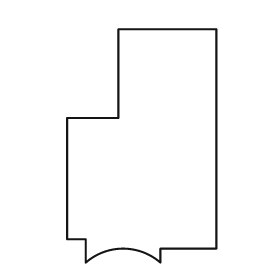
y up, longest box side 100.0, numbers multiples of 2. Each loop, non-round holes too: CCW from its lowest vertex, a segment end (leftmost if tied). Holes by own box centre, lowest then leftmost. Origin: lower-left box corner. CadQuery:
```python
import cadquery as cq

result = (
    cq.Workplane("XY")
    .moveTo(8.0, 0.0)
    .threePointArc((24.0, 6.0), (40.0, 0.0))
    .lineTo(40.0, 6.0)
    .lineTo(64.0, 6.0)
    .lineTo(64.0, 100.0)
    .lineTo(22.0, 100.0)
    .lineTo(22.0, 62.0)
    .lineTo(0.0, 62.0)
    .lineTo(0.0, 10.0)
    .lineTo(8.0, 10.0)
    .close()
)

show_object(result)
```